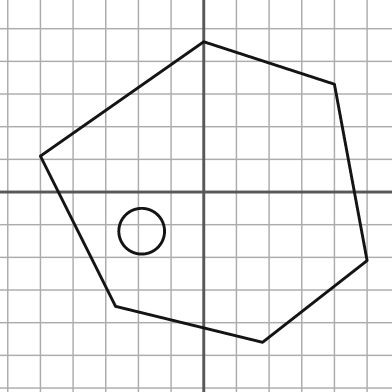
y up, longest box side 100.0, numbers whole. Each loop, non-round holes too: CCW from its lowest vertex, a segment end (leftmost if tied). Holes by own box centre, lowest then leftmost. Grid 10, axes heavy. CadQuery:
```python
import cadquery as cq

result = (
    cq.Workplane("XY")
    .moveTo(18.0, -46.0)
    .lineTo(50.0, -21.0)
    .lineTo(40.0, 33.0)
    .lineTo(0.0, 46.0)
    .lineTo(-50.0, 11.0)
    .lineTo(-27.0, -35.0)
    .close()
    .moveTo(-19.0, -12.0)
    .circle(7.0)
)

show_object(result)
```